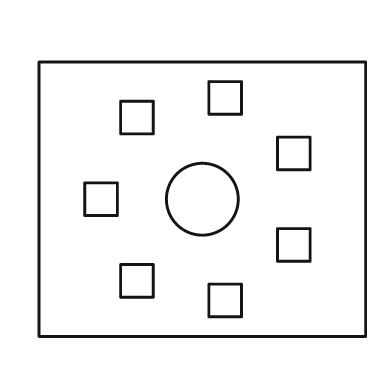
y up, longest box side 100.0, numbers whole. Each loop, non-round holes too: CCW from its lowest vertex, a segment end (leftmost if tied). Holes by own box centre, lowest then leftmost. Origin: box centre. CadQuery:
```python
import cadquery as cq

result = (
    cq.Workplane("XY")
    .moveTo(-50.0, -42.0)
    .lineTo(50.0, -42.0)
    .lineTo(50.0, 42.0)
    .lineTo(-50.0, 42.0)
    .close()
    .moveTo(2.0, -36.0)
    .lineTo(12.0, -36.0)
    .lineTo(12.0, -26.0)
    .lineTo(2.0, -26.0)
    .close()
    .moveTo(-25.0, -30.0)
    .lineTo(-15.0, -30.0)
    .lineTo(-15.0, -20.0)
    .lineTo(-25.0, -20.0)
    .close()
    .moveTo(23.0, -19.0)
    .lineTo(33.0, -19.0)
    .lineTo(33.0, -9.0)
    .lineTo(23.0, -9.0)
    .close()
    .moveTo(-36.0, -5.0)
    .lineTo(-26.0, -5.0)
    .lineTo(-26.0, 5.0)
    .lineTo(-36.0, 5.0)
    .close()
    .moveTo(0.0, 0.0)
    .circle(11.0)
    .moveTo(23.0, 9.0)
    .lineTo(33.0, 9.0)
    .lineTo(33.0, 19.0)
    .lineTo(23.0, 19.0)
    .close()
    .moveTo(-25.0, 20.0)
    .lineTo(-15.0, 20.0)
    .lineTo(-15.0, 30.0)
    .lineTo(-25.0, 30.0)
    .close()
    .moveTo(2.0, 26.0)
    .lineTo(12.0, 26.0)
    .lineTo(12.0, 36.0)
    .lineTo(2.0, 36.0)
    .close()
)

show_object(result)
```